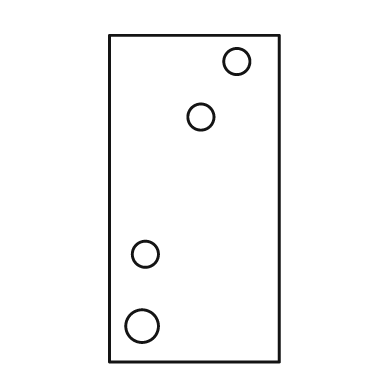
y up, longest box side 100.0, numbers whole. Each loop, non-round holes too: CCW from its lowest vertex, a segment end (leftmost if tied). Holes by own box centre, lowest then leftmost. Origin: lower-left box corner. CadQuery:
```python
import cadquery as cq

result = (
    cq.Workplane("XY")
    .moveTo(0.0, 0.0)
    .lineTo(52.0, 0.0)
    .lineTo(52.0, 100.0)
    .lineTo(0.0, 100.0)
    .close()
    .moveTo(10.0, 11.0)
    .circle(5.0)
    .moveTo(11.0, 33.0)
    .circle(4.0)
    .moveTo(28.0, 75.0)
    .circle(4.0)
    .moveTo(39.0, 92.0)
    .circle(4.0)
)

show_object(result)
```